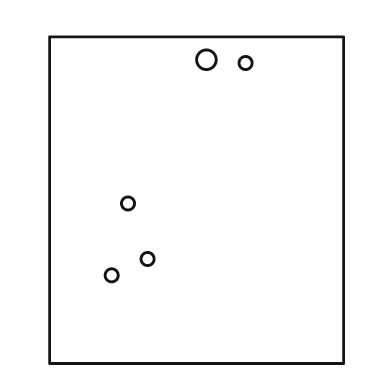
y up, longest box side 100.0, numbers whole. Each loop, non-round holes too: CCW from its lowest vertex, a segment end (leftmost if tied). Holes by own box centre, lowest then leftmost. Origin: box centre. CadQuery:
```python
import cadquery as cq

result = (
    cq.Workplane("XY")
    .moveTo(-45.0, -50.0)
    .lineTo(45.0, -50.0)
    .lineTo(45.0, 50.0)
    .lineTo(-45.0, 50.0)
    .close()
    .moveTo(-26.0, -23.0)
    .circle(2.0)
    .moveTo(-15.0, -18.0)
    .circle(2.0)
    .moveTo(-21.0, -1.0)
    .circle(2.0)
    .moveTo(15.0, 42.0)
    .circle(2.0)
    .moveTo(3.0, 43.0)
    .circle(3.0)
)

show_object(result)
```